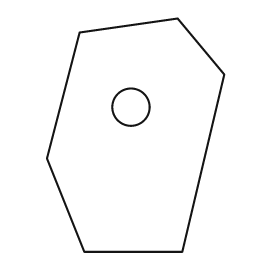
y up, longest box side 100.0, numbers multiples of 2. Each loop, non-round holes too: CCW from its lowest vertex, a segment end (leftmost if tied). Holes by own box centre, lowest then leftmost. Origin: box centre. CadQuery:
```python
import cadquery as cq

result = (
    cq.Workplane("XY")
    .moveTo(-22.0, -50.0)
    .lineTo(20.0, -50.0)
    .lineTo(38.0, 26.0)
    .lineTo(18.0, 50.0)
    .lineTo(-24.0, 44.0)
    .lineTo(-38.0, -10.0)
    .close()
    .moveTo(-2.0, 12.0)
    .circle(8.0)
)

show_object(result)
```